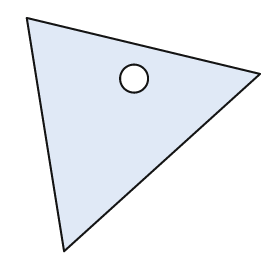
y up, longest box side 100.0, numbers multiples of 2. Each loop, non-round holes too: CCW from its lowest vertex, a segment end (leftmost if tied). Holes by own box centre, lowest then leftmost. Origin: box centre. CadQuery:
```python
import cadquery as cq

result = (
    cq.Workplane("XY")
    .moveTo(-34.0, -50.0)
    .lineTo(50.0, 26.0)
    .lineTo(-50.0, 50.0)
    .close()
    .moveTo(-4.0, 24.0)
    .circle(6.0)
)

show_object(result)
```